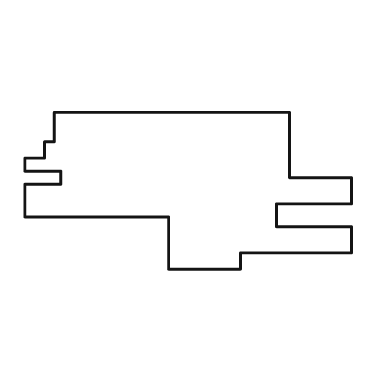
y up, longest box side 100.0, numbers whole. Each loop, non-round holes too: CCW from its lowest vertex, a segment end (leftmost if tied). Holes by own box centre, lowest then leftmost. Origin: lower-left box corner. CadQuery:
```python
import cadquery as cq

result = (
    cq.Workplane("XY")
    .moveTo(44.0, 0.0)
    .lineTo(66.0, 0.0)
    .lineTo(66.0, 5.0)
    .lineTo(100.0, 5.0)
    .lineTo(100.0, 13.0)
    .lineTo(77.0, 13.0)
    .lineTo(77.0, 20.0)
    .lineTo(100.0, 20.0)
    .lineTo(100.0, 28.0)
    .lineTo(81.0, 28.0)
    .lineTo(81.0, 48.0)
    .lineTo(9.0, 48.0)
    .lineTo(9.0, 39.0)
    .lineTo(6.0, 39.0)
    .lineTo(6.0, 34.0)
    .lineTo(0.0, 34.0)
    .lineTo(0.0, 30.0)
    .lineTo(11.0, 30.0)
    .lineTo(11.0, 26.0)
    .lineTo(0.0, 26.0)
    .lineTo(0.0, 16.0)
    .lineTo(44.0, 16.0)
    .close()
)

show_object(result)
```